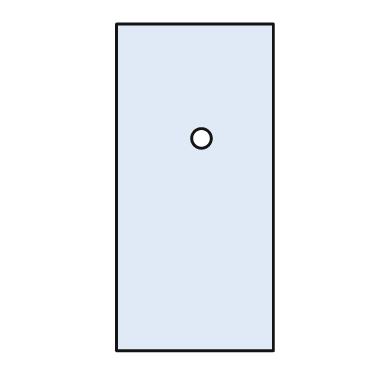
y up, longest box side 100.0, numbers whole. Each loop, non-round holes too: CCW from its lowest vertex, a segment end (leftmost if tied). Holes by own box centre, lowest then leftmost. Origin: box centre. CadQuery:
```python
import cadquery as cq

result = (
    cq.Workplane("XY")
    .moveTo(-24.0, -50.0)
    .lineTo(24.0, -50.0)
    .lineTo(24.0, 50.0)
    .lineTo(-24.0, 50.0)
    .close()
    .moveTo(2.0, 15.0)
    .circle(3.0)
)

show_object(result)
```